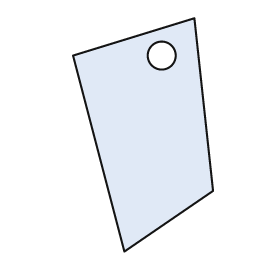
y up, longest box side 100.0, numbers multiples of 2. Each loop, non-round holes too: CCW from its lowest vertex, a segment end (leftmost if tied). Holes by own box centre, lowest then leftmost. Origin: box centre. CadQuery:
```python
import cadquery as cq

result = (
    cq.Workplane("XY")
    .moveTo(-8.0, -50.0)
    .lineTo(30.0, -24.0)
    .lineTo(22.0, 50.0)
    .lineTo(-30.0, 34.0)
    .close()
    .moveTo(8.0, 34.0)
    .circle(6.0)
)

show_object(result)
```